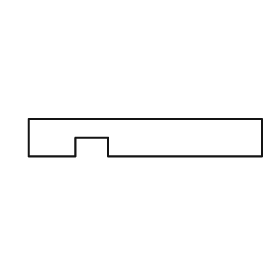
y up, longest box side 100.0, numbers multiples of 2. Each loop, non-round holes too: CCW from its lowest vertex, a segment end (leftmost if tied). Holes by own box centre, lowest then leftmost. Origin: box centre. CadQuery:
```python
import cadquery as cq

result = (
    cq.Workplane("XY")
    .moveTo(-50.0, -8.0)
    .lineTo(-30.0, -8.0)
    .lineTo(-30.0, 0.0)
    .lineTo(-16.0, 0.0)
    .lineTo(-16.0, -8.0)
    .lineTo(50.0, -8.0)
    .lineTo(50.0, 8.0)
    .lineTo(-50.0, 8.0)
    .close()
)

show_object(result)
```